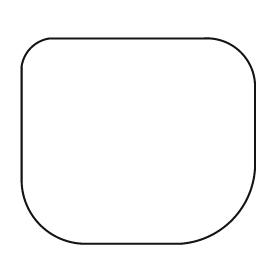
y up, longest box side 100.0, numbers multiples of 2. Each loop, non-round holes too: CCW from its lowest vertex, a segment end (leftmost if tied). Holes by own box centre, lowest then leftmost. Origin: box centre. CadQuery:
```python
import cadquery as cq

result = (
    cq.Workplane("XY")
    .moveTo(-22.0, -44.0)
    .lineTo(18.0, -44.0)
    .threePointArc((40.0, -34.0), (50.0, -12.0))
    .lineTo(50.0, 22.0)
    .threePointArc((44.0, 38.0), (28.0, 44.0))
    .lineTo(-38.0, 44.0)
    .threePointArc((-46.0, 40.0), (-50.0, 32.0))
    .lineTo(-50.0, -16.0)
    .threePointArc((-42.0, -36.0), (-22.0, -44.0))
    .close()
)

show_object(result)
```